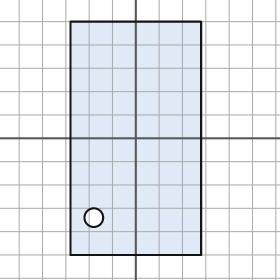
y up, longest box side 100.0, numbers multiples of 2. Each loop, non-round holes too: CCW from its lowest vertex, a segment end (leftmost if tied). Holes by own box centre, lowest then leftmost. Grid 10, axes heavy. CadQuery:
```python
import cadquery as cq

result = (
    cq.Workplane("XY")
    .moveTo(-28.0, -50.0)
    .lineTo(28.0, -50.0)
    .lineTo(28.0, 50.0)
    .lineTo(-28.0, 50.0)
    .close()
    .moveTo(-18.0, -34.0)
    .circle(4.0)
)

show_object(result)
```